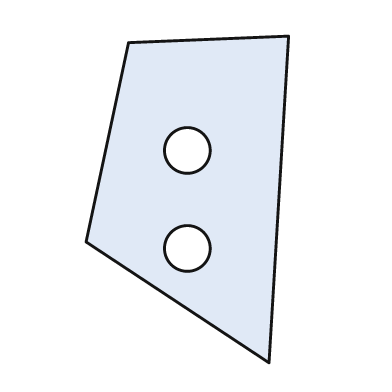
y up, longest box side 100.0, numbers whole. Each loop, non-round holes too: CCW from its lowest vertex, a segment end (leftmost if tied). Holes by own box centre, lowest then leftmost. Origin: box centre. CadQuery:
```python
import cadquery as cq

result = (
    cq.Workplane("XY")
    .moveTo(25.0, -50.0)
    .lineTo(31.0, 50.0)
    .lineTo(-18.0, 48.0)
    .lineTo(-31.0, -13.0)
    .close()
    .moveTo(0.0, -15.0)
    .circle(7.0)
    .moveTo(0.0, 15.0)
    .circle(7.0)
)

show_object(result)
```